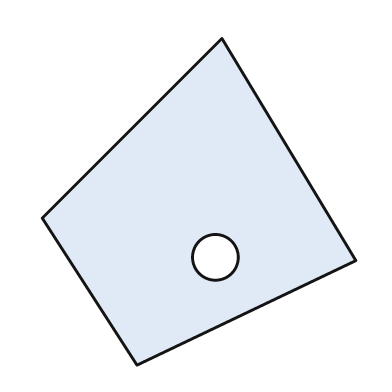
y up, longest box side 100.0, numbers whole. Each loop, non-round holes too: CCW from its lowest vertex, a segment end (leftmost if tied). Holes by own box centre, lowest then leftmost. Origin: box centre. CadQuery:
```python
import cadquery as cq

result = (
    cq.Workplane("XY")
    .moveTo(-19.0, -50.0)
    .lineTo(48.0, -18.0)
    .lineTo(7.0, 50.0)
    .lineTo(-48.0, -5.0)
    .close()
    .moveTo(5.0, -17.0)
    .circle(7.0)
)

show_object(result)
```